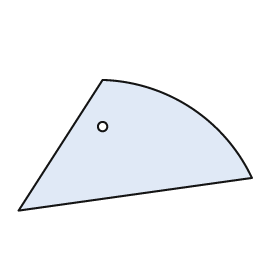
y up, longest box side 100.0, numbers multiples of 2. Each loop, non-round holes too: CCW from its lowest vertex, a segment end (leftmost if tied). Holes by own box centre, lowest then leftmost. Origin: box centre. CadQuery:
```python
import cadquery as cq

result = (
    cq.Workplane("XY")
    .moveTo(-50.0, -28.0)
    .lineTo(50.0, -14.0)
    .threePointArc((24.0, 16.0), (-14.0, 28.0))
    .close()
    .moveTo(-14.0, 8.0)
    .circle(2.0)
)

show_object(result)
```